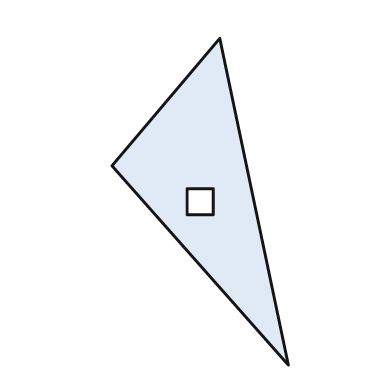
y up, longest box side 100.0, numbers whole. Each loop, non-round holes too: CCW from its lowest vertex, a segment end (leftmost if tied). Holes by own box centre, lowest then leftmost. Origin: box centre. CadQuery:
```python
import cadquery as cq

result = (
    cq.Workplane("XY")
    .moveTo(27.0, -50.0)
    .lineTo(6.0, 50.0)
    .lineTo(-27.0, 11.0)
    .close()
    .moveTo(-4.0, -4.0)
    .lineTo(4.0, -4.0)
    .lineTo(4.0, 4.0)
    .lineTo(-4.0, 4.0)
    .close()
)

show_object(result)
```